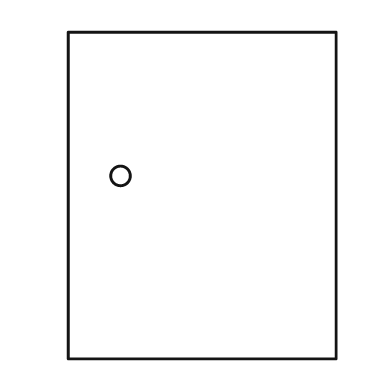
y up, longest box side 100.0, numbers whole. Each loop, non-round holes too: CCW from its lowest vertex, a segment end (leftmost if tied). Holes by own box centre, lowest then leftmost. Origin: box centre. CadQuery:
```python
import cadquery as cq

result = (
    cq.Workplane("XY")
    .moveTo(-41.0, -50.0)
    .lineTo(41.0, -50.0)
    .lineTo(41.0, 50.0)
    .lineTo(-41.0, 50.0)
    .close()
    .moveTo(-25.0, 6.0)
    .circle(3.0)
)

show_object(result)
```